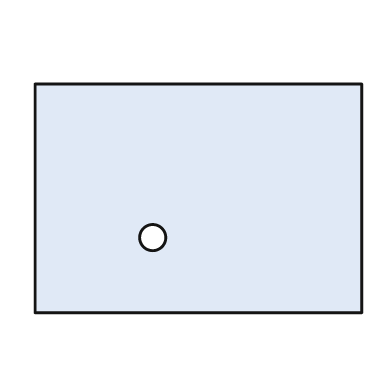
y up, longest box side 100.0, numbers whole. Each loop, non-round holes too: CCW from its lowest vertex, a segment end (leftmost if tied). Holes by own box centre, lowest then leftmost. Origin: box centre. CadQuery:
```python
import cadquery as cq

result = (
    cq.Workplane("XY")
    .moveTo(-50.0, -35.0)
    .lineTo(50.0, -35.0)
    .lineTo(50.0, 35.0)
    .lineTo(-50.0, 35.0)
    .close()
    .moveTo(-14.0, -12.0)
    .circle(4.0)
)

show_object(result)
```